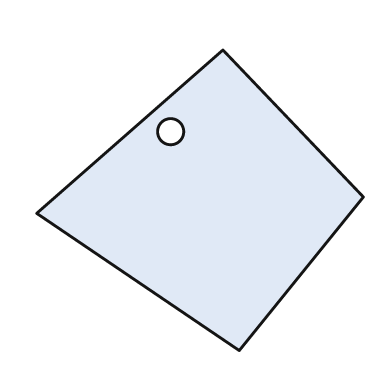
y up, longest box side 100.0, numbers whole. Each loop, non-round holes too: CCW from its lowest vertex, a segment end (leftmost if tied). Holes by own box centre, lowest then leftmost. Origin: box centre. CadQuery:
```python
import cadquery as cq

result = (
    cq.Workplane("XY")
    .moveTo(12.0, -46.0)
    .lineTo(50.0, 1.0)
    .lineTo(7.0, 46.0)
    .lineTo(-50.0, -4.0)
    .close()
    .moveTo(-9.0, 21.0)
    .circle(4.0)
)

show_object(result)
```